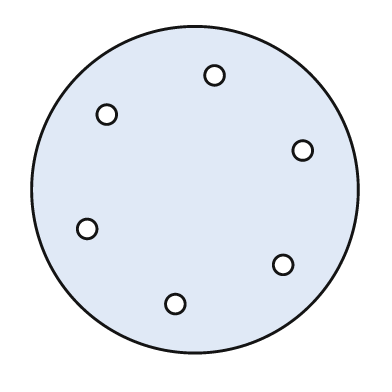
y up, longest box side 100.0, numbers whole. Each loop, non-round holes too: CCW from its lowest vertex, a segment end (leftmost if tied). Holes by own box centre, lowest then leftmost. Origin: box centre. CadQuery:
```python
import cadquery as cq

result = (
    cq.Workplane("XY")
    .moveTo(0.0, 0.0)
    .circle(50.0)
    .moveTo(-6.0, -35.0)
    .circle(3.0)
    .moveTo(27.0, -23.0)
    .circle(3.0)
    .moveTo(-33.0, -12.0)
    .circle(3.0)
    .moveTo(33.0, 12.0)
    .circle(3.0)
    .moveTo(-27.0, 23.0)
    .circle(3.0)
    .moveTo(6.0, 35.0)
    .circle(3.0)
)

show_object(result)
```